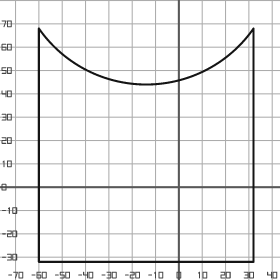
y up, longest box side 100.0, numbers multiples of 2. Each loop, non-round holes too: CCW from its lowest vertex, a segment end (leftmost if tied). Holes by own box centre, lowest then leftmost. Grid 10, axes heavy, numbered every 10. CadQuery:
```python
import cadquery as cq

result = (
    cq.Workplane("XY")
    .moveTo(-60.0, -32.0)
    .lineTo(32.0, -32.0)
    .lineTo(32.0, 68.0)
    .threePointArc((-14.0, 44.0), (-60.0, 68.0))
    .close()
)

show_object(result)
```